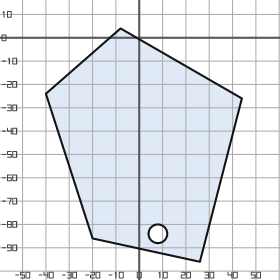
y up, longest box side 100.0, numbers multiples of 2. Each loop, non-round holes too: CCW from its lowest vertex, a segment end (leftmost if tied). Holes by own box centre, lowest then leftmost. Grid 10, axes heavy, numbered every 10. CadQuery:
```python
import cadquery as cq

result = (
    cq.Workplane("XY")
    .moveTo(26.0, -96.0)
    .lineTo(44.0, -26.0)
    .lineTo(-8.0, 4.0)
    .lineTo(-40.0, -24.0)
    .lineTo(-20.0, -86.0)
    .close()
    .moveTo(8.0, -84.0)
    .circle(4.0)
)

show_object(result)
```